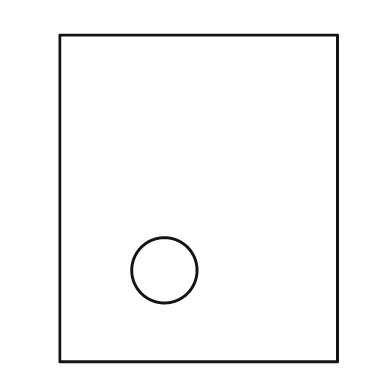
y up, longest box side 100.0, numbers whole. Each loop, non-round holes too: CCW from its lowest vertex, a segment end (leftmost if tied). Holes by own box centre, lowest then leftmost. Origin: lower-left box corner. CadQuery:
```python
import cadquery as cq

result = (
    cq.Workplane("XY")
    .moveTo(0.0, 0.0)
    .lineTo(85.0, 0.0)
    .lineTo(85.0, 100.0)
    .lineTo(0.0, 100.0)
    .close()
    .moveTo(32.0, 28.0)
    .circle(10.0)
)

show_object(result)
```